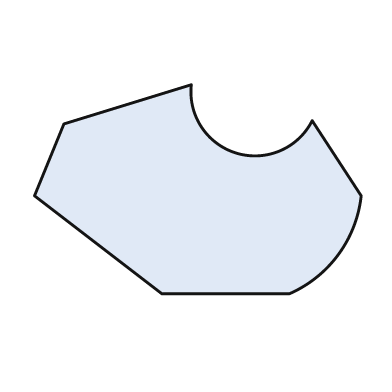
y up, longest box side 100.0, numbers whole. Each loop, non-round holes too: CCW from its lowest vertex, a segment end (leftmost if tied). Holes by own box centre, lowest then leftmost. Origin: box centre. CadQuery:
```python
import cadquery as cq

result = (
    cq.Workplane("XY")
    .moveTo(-11.0, -32.0)
    .lineTo(28.0, -32.0)
    .threePointArc((43.0, -20.0), (50.0, -2.0))
    .lineTo(35.0, 21.0)
    .threePointArc((12.0, 11.0), (-2.0, 32.0))
    .lineTo(-41.0, 20.0)
    .lineTo(-50.0, -2.0)
    .close()
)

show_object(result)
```